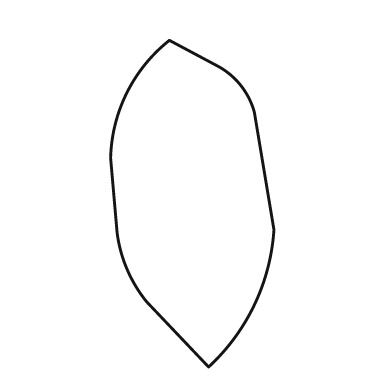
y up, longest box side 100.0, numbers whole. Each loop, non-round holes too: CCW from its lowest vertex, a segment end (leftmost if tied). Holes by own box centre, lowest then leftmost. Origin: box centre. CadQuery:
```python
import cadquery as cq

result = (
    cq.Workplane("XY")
    .moveTo(5.0, -50.0)
    .threePointArc((19.0, -31.0), (25.0, -8.0))
    .lineTo(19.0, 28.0)
    .threePointArc((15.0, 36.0), (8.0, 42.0))
    .lineTo(-7.0, 50.0)
    .threePointArc((-20.0, 34.0), (-25.0, 14.0))
    .lineTo(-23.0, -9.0)
    .threePointArc((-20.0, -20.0), (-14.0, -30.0))
    .close()
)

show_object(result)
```